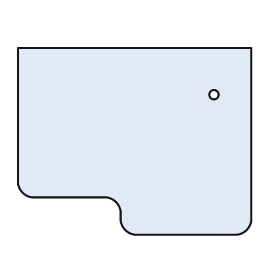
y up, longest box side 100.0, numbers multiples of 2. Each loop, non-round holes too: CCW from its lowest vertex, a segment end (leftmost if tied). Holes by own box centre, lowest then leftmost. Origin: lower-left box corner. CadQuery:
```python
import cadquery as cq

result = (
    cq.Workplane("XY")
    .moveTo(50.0, 0.0)
    .lineTo(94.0, 0.0)
    .threePointArc((98.0, 2.0), (100.0, 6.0))
    .lineTo(100.0, 80.0)
    .lineTo(0.0, 80.0)
    .lineTo(0.0, 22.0)
    .threePointArc((2.0, 18.0), (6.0, 16.0))
    .lineTo(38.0, 16.0)
    .threePointArc((42.0, 14.0), (44.0, 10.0))
    .lineTo(44.0, 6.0)
    .threePointArc((46.0, 2.0), (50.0, 0.0))
    .close()
    .moveTo(84.0, 60.0)
    .circle(2.0)
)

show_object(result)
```